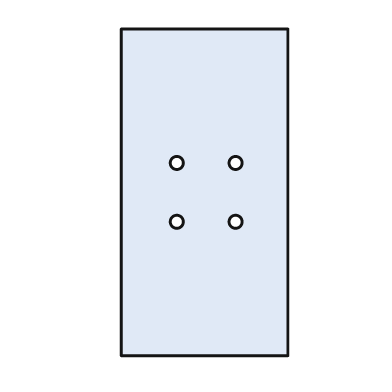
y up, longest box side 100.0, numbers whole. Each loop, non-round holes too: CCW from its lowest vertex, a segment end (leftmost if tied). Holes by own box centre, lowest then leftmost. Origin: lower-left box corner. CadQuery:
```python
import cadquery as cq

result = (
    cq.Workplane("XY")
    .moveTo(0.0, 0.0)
    .lineTo(51.0, 0.0)
    .lineTo(51.0, 100.0)
    .lineTo(0.0, 100.0)
    .close()
    .moveTo(17.0, 41.0)
    .circle(2.0)
    .moveTo(35.0, 41.0)
    .circle(2.0)
    .moveTo(17.0, 59.0)
    .circle(2.0)
    .moveTo(35.0, 59.0)
    .circle(2.0)
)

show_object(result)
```